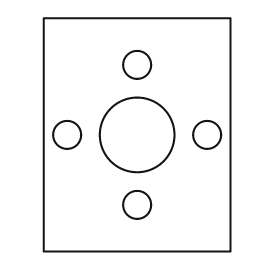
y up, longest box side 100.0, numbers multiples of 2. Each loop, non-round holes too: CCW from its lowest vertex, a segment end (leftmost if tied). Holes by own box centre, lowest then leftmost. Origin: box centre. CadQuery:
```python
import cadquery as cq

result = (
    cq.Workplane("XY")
    .moveTo(-40.0, -50.0)
    .lineTo(40.0, -50.0)
    .lineTo(40.0, 50.0)
    .lineTo(-40.0, 50.0)
    .close()
    .moveTo(0.0, -30.0)
    .circle(6.0)
    .moveTo(-30.0, 0.0)
    .circle(6.0)
    .moveTo(0.0, 0.0)
    .circle(16.0)
    .moveTo(30.0, 0.0)
    .circle(6.0)
    .moveTo(0.0, 30.0)
    .circle(6.0)
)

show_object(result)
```